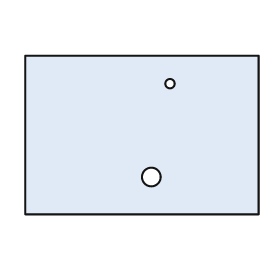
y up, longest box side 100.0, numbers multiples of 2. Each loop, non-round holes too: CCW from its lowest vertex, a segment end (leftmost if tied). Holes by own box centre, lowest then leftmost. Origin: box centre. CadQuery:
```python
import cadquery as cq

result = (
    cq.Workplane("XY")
    .moveTo(-50.0, -34.0)
    .lineTo(50.0, -34.0)
    .lineTo(50.0, 34.0)
    .lineTo(-50.0, 34.0)
    .close()
    .moveTo(4.0, -18.0)
    .circle(4.0)
    .moveTo(12.0, 22.0)
    .circle(2.0)
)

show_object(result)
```